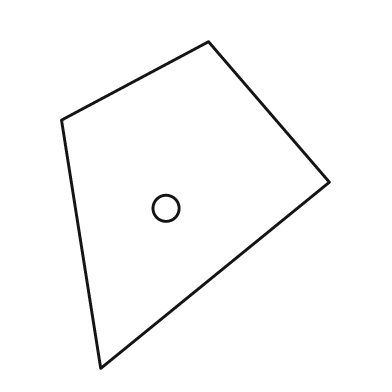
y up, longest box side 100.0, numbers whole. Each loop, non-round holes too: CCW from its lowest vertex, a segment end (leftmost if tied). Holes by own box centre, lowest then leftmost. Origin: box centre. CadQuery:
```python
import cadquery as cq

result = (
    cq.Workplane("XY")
    .moveTo(-29.0, -50.0)
    .lineTo(41.0, 7.0)
    .lineTo(4.0, 50.0)
    .lineTo(-41.0, 26.0)
    .close()
    .moveTo(-9.0, -1.0)
    .circle(4.0)
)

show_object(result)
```